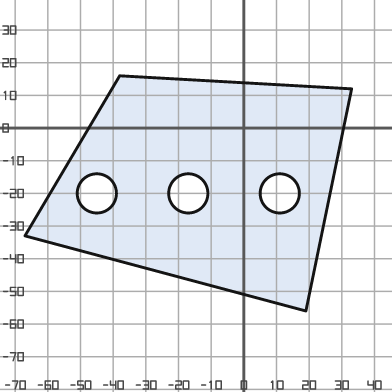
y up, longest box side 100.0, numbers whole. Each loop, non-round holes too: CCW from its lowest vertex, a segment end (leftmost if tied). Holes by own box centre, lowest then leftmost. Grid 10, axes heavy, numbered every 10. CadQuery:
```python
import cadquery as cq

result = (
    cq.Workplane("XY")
    .moveTo(19.0, -56.0)
    .lineTo(33.0, 12.0)
    .lineTo(-38.0, 16.0)
    .lineTo(-67.0, -33.0)
    .close()
    .moveTo(-45.0, -20.0)
    .circle(6.0)
    .moveTo(-17.0, -20.0)
    .circle(6.0)
    .moveTo(11.0, -20.0)
    .circle(6.0)
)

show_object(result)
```